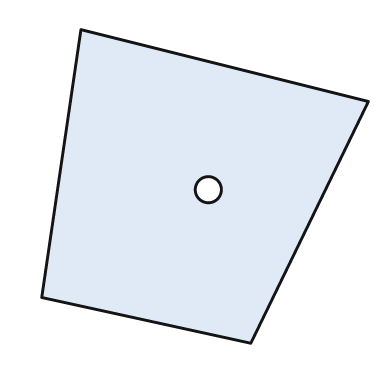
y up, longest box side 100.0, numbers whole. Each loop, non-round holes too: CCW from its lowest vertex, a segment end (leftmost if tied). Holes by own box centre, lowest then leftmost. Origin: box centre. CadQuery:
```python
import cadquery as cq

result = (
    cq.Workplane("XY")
    .moveTo(14.0, -48.0)
    .lineTo(50.0, 26.0)
    .lineTo(-38.0, 48.0)
    .lineTo(-50.0, -34.0)
    .close()
    .moveTo(1.0, -1.0)
    .circle(4.0)
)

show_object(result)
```